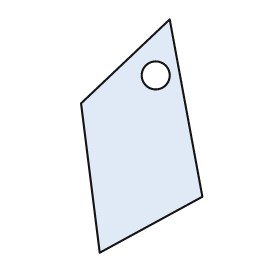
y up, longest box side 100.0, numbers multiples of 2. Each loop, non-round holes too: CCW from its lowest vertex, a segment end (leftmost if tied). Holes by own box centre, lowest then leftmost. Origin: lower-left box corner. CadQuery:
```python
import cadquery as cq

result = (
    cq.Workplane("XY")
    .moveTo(8.0, 0.0)
    .lineTo(52.0, 24.0)
    .lineTo(38.0, 100.0)
    .lineTo(0.0, 64.0)
    .close()
    .moveTo(32.0, 76.0)
    .circle(6.0)
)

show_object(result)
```